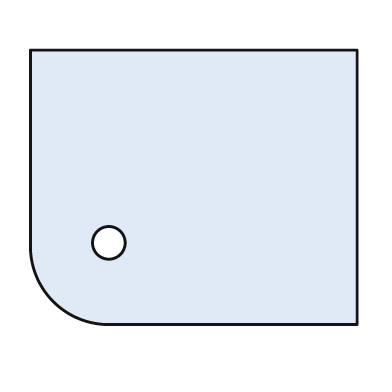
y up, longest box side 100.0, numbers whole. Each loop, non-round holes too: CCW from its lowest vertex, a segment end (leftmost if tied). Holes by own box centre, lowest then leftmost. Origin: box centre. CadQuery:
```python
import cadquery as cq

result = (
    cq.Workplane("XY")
    .moveTo(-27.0, -42.0)
    .lineTo(50.0, -42.0)
    .lineTo(50.0, 42.0)
    .lineTo(-50.0, 42.0)
    .lineTo(-50.0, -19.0)
    .threePointArc((-43.0, -35.0), (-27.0, -42.0))
    .close()
    .moveTo(-26.0, -17.0)
    .circle(5.0)
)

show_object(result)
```